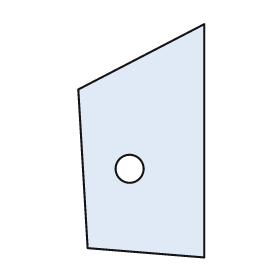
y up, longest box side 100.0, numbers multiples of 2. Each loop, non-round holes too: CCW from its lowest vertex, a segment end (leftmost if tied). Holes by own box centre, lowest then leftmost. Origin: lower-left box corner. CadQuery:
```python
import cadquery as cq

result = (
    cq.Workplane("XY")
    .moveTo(54.0, 0.0)
    .lineTo(54.0, 100.0)
    .lineTo(0.0, 72.0)
    .lineTo(4.0, 4.0)
    .close()
    .moveTo(22.0, 38.0)
    .circle(6.0)
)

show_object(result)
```